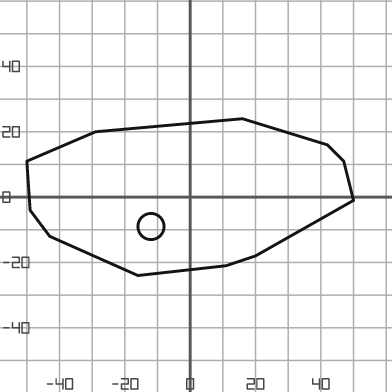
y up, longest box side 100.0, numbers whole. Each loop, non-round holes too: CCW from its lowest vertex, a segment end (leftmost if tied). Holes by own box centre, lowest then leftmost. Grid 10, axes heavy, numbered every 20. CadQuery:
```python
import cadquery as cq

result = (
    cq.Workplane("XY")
    .moveTo(-16.0, -24.0)
    .lineTo(11.0, -21.0)
    .lineTo(20.0, -18.0)
    .lineTo(50.0, -1.0)
    .lineTo(47.0, 11.0)
    .lineTo(42.0, 16.0)
    .lineTo(16.0, 24.0)
    .lineTo(-29.0, 20.0)
    .lineTo(-50.0, 11.0)
    .lineTo(-49.0, -4.0)
    .lineTo(-43.0, -12.0)
    .close()
    .moveTo(-12.0, -9.0)
    .circle(4.0)
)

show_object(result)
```